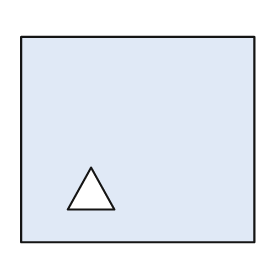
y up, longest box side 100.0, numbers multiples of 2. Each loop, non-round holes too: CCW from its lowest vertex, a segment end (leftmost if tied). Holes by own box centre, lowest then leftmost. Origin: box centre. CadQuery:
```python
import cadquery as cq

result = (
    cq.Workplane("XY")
    .moveTo(-50.0, -44.0)
    .lineTo(50.0, -44.0)
    .lineTo(50.0, 44.0)
    .lineTo(-50.0, 44.0)
    .close()
    .moveTo(-30.0, -30.0)
    .lineTo(-10.0, -30.0)
    .lineTo(-20.0, -12.0)
    .close()
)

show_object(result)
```